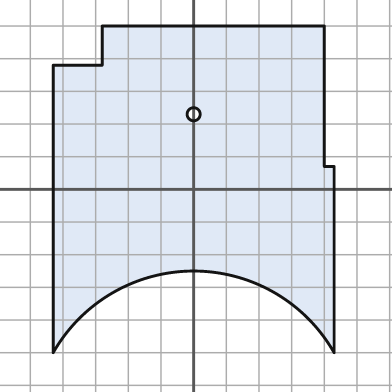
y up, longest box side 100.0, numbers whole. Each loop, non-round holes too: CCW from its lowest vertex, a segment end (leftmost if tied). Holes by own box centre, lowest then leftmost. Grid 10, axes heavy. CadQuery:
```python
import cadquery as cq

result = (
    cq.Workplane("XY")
    .moveTo(-43.0, -50.0)
    .threePointArc((0.0, -25.0), (43.0, -50.0))
    .lineTo(43.0, 7.0)
    .lineTo(40.0, 7.0)
    .lineTo(40.0, 50.0)
    .lineTo(-28.0, 50.0)
    .lineTo(-28.0, 38.0)
    .lineTo(-43.0, 38.0)
    .close()
    .moveTo(0.0, 23.0)
    .circle(2.0)
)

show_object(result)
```